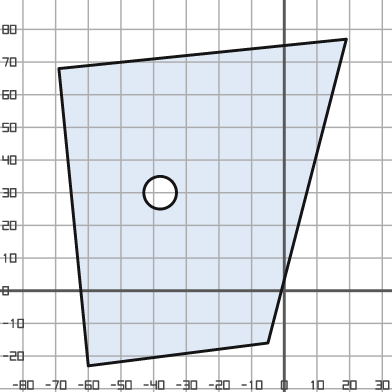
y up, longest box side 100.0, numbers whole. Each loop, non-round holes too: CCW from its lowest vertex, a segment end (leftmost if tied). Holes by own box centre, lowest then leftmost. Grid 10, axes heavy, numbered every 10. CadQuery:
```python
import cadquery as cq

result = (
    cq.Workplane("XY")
    .moveTo(-60.0, -23.0)
    .lineTo(-5.0, -16.0)
    .lineTo(19.0, 77.0)
    .lineTo(-69.0, 68.0)
    .close()
    .moveTo(-38.0, 30.0)
    .circle(5.0)
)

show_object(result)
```